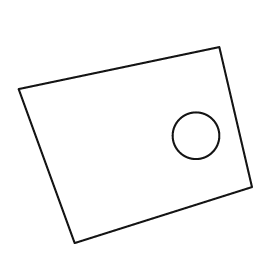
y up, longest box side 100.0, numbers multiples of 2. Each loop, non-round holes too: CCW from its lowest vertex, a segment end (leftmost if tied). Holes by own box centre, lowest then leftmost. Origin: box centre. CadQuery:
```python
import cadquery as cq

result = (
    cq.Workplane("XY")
    .moveTo(-26.0, -42.0)
    .lineTo(50.0, -18.0)
    .lineTo(36.0, 42.0)
    .lineTo(-50.0, 24.0)
    .close()
    .moveTo(26.0, 4.0)
    .circle(10.0)
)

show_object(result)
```